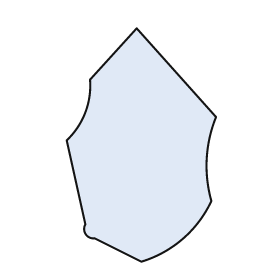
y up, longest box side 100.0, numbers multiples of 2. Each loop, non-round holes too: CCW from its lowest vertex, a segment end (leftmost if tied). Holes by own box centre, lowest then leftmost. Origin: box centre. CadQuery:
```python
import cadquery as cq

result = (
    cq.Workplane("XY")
    .moveTo(0.0, -50.0)
    .threePointArc((18.0, -40.0), (30.0, -24.0))
    .threePointArc((28.0, -6.0), (32.0, 12.0))
    .lineTo(-2.0, 50.0)
    .lineTo(-22.0, 28.0)
    .threePointArc((-24.0, 14.0), (-32.0, 2.0))
    .lineTo(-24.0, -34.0)
    .threePointArc((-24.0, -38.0), (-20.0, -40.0))
    .close()
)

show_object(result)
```